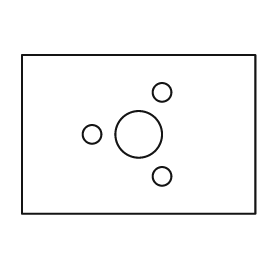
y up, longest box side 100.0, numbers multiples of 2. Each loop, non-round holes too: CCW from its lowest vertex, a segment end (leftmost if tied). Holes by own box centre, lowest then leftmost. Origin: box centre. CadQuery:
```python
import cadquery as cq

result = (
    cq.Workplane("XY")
    .moveTo(-50.0, -34.0)
    .lineTo(50.0, -34.0)
    .lineTo(50.0, 34.0)
    .lineTo(-50.0, 34.0)
    .close()
    .moveTo(10.0, -18.0)
    .circle(4.0)
    .moveTo(-20.0, 0.0)
    .circle(4.0)
    .moveTo(0.0, 0.0)
    .circle(10.0)
    .moveTo(10.0, 18.0)
    .circle(4.0)
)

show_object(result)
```